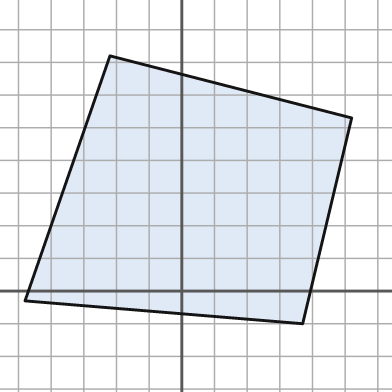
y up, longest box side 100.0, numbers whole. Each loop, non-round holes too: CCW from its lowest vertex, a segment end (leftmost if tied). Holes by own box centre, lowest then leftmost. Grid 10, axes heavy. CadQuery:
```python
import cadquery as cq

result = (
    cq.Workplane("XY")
    .moveTo(37.0, -10.0)
    .lineTo(52.0, 53.0)
    .lineTo(-22.0, 72.0)
    .lineTo(-48.0, -3.0)
    .close()
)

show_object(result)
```